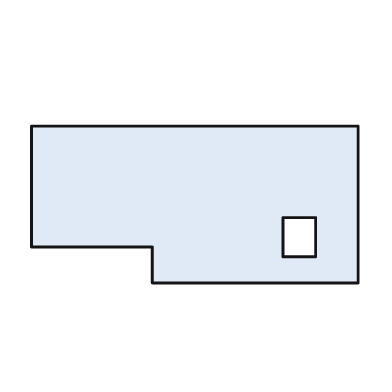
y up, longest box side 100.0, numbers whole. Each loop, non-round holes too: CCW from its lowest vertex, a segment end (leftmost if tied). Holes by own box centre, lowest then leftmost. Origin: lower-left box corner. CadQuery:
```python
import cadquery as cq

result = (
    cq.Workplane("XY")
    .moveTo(37.0, 0.0)
    .lineTo(100.0, 0.0)
    .lineTo(100.0, 48.0)
    .lineTo(0.0, 48.0)
    .lineTo(0.0, 11.0)
    .lineTo(37.0, 11.0)
    .close()
    .moveTo(77.0, 8.0)
    .lineTo(87.0, 8.0)
    .lineTo(87.0, 20.0)
    .lineTo(77.0, 20.0)
    .close()
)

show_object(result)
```